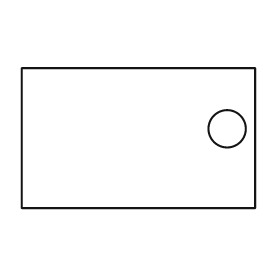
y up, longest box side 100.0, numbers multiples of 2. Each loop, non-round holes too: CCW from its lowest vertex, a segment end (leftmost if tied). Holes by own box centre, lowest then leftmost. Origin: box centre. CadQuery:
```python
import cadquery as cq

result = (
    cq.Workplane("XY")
    .moveTo(-50.0, -30.0)
    .lineTo(50.0, -30.0)
    .lineTo(50.0, 30.0)
    .lineTo(-50.0, 30.0)
    .close()
    .moveTo(38.0, 4.0)
    .circle(8.0)
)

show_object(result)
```